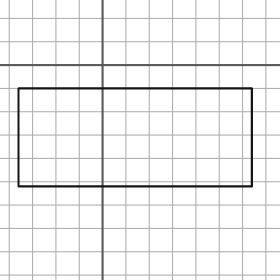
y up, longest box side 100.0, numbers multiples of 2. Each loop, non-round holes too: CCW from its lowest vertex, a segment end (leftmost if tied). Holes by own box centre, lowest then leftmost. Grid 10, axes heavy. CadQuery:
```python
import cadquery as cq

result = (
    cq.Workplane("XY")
    .moveTo(-36.0, -52.0)
    .lineTo(64.0, -52.0)
    .lineTo(64.0, -10.0)
    .lineTo(-36.0, -10.0)
    .close()
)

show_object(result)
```